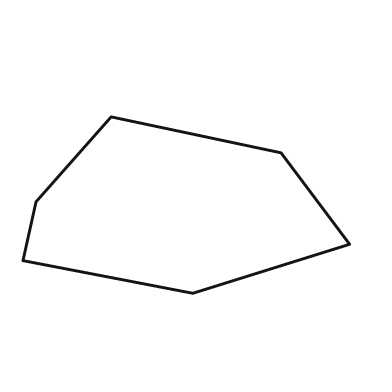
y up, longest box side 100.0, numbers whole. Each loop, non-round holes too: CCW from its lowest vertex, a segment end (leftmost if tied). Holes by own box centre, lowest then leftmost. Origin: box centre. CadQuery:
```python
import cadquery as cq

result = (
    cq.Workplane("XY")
    .moveTo(2.0, -27.0)
    .lineTo(50.0, -12.0)
    .lineTo(29.0, 16.0)
    .lineTo(-23.0, 27.0)
    .lineTo(-46.0, 1.0)
    .lineTo(-50.0, -17.0)
    .close()
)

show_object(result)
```